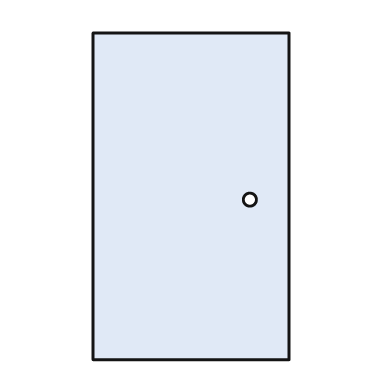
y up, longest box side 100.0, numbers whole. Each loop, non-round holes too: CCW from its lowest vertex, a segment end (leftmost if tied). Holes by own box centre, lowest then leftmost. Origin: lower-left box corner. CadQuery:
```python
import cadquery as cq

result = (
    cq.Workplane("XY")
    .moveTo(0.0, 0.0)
    .lineTo(60.0, 0.0)
    .lineTo(60.0, 100.0)
    .lineTo(0.0, 100.0)
    .close()
    .moveTo(48.0, 49.0)
    .circle(2.0)
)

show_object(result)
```